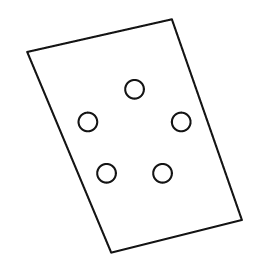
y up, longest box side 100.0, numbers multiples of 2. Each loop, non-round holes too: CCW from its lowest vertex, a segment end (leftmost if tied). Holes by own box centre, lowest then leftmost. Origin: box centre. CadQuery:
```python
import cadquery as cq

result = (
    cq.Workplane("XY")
    .moveTo(-10.0, -50.0)
    .lineTo(46.0, -36.0)
    .lineTo(16.0, 50.0)
    .lineTo(-46.0, 36.0)
    .close()
    .moveTo(-12.0, -16.0)
    .circle(4.0)
    .moveTo(12.0, -16.0)
    .circle(4.0)
    .moveTo(-20.0, 6.0)
    .circle(4.0)
    .moveTo(20.0, 6.0)
    .circle(4.0)
    .moveTo(0.0, 20.0)
    .circle(4.0)
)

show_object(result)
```